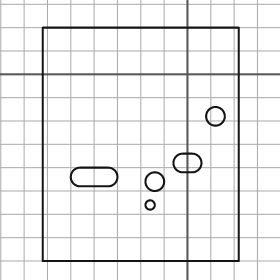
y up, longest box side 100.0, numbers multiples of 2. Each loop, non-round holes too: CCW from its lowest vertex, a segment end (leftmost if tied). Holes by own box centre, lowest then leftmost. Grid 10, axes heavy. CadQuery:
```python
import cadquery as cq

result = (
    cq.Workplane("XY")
    .moveTo(-62.0, -80.0)
    .lineTo(22.0, -80.0)
    .lineTo(22.0, 20.0)
    .lineTo(-62.0, 20.0)
    .close()
    .moveTo(-16.0, -56.0)
    .circle(2.0)
    .moveTo(-14.0, -46.0)
    .circle(4.0)
    .moveTo(-46.0, -48.0)
    .lineTo(-34.0, -48.0)
    .threePointArc((-30.0, -44.0), (-34.0, -40.0))
    .lineTo(-46.0, -40.0)
    .threePointArc((-50.0, -44.0), (-46.0, -48.0))
    .close()
    .moveTo(-2.0, -42.0)
    .lineTo(2.0, -42.0)
    .threePointArc((6.0, -38.0), (2.0, -34.0))
    .lineTo(-2.0, -34.0)
    .threePointArc((-6.0, -38.0), (-2.0, -42.0))
    .close()
    .moveTo(12.0, -18.0)
    .circle(4.0)
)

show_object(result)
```